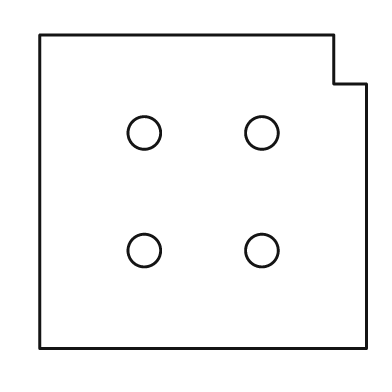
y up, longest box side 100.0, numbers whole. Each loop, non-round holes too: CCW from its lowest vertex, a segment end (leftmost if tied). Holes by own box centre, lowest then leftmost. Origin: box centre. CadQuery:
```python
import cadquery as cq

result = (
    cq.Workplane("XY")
    .moveTo(-50.0, -48.0)
    .lineTo(50.0, -48.0)
    .lineTo(50.0, 33.0)
    .lineTo(40.0, 33.0)
    .lineTo(40.0, 48.0)
    .lineTo(-50.0, 48.0)
    .close()
    .moveTo(-18.0, -18.0)
    .circle(5.0)
    .moveTo(18.0, -18.0)
    .circle(5.0)
    .moveTo(-18.0, 18.0)
    .circle(5.0)
    .moveTo(18.0, 18.0)
    .circle(5.0)
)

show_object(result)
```